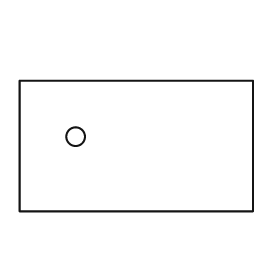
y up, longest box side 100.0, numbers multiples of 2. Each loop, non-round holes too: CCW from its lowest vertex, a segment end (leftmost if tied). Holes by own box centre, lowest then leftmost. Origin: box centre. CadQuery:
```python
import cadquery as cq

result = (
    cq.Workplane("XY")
    .moveTo(-50.0, -28.0)
    .lineTo(50.0, -28.0)
    .lineTo(50.0, 28.0)
    .lineTo(-50.0, 28.0)
    .close()
    .moveTo(-26.0, 4.0)
    .circle(4.0)
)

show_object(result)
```